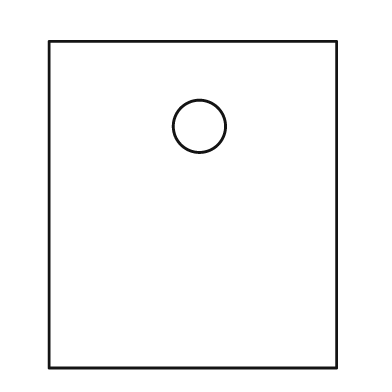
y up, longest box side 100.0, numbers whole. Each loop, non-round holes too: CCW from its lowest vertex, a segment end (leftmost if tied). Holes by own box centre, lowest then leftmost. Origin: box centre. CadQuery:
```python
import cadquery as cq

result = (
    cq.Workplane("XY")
    .moveTo(-44.0, -50.0)
    .lineTo(44.0, -50.0)
    .lineTo(44.0, 50.0)
    .lineTo(-44.0, 50.0)
    .close()
    .moveTo(2.0, 24.0)
    .circle(8.0)
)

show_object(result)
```